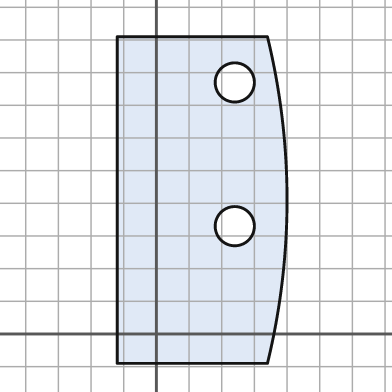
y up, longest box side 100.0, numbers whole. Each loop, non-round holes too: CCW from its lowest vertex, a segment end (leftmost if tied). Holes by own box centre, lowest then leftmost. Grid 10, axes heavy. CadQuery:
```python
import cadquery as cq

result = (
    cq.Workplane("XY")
    .moveTo(-12.0, -9.0)
    .lineTo(34.0, -9.0)
    .threePointArc((40.0, 41.0), (34.0, 91.0))
    .lineTo(-12.0, 91.0)
    .close()
    .moveTo(24.0, 33.0)
    .circle(6.0)
    .moveTo(24.0, 77.0)
    .circle(6.0)
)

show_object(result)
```